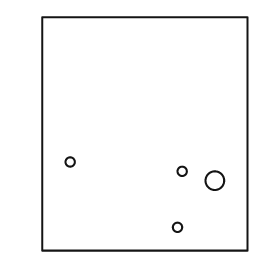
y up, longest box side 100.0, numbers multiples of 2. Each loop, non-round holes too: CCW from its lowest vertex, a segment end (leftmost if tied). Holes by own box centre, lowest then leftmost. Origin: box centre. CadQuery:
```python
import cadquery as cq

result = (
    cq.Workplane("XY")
    .moveTo(-44.0, -50.0)
    .lineTo(44.0, -50.0)
    .lineTo(44.0, 50.0)
    .lineTo(-44.0, 50.0)
    .close()
    .moveTo(14.0, -40.0)
    .circle(2.0)
    .moveTo(30.0, -20.0)
    .circle(4.0)
    .moveTo(16.0, -16.0)
    .circle(2.0)
    .moveTo(-32.0, -12.0)
    .circle(2.0)
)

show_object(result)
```